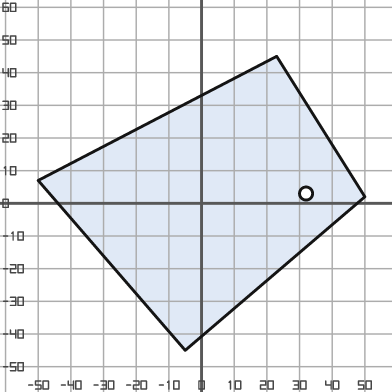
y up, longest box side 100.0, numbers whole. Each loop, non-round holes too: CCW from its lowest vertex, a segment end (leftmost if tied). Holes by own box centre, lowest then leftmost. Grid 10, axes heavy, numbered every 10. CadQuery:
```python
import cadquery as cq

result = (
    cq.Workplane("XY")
    .moveTo(-5.0, -45.0)
    .lineTo(50.0, 2.0)
    .lineTo(23.0, 45.0)
    .lineTo(-50.0, 7.0)
    .close()
    .moveTo(32.0, 3.0)
    .circle(2.0)
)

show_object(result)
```